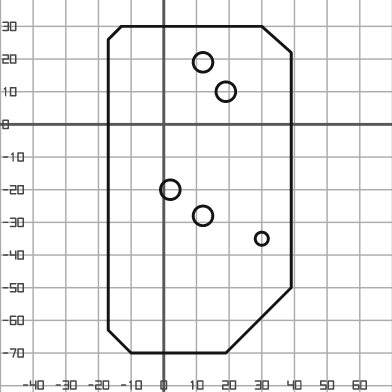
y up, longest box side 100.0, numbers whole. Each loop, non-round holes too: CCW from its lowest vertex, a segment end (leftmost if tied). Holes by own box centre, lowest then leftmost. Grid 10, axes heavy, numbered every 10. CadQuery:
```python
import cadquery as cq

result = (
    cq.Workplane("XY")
    .moveTo(-10.0, -70.0)
    .lineTo(19.0, -70.0)
    .lineTo(39.0, -50.0)
    .lineTo(39.0, 22.0)
    .lineTo(30.0, 30.0)
    .lineTo(-13.0, 30.0)
    .lineTo(-17.0, 26.0)
    .lineTo(-17.0, -63.0)
    .close()
    .moveTo(30.0, -35.0)
    .circle(2.0)
    .moveTo(12.0, -28.0)
    .circle(3.0)
    .moveTo(2.0, -20.0)
    .circle(3.0)
    .moveTo(19.0, 10.0)
    .circle(3.0)
    .moveTo(12.0, 19.0)
    .circle(3.0)
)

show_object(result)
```